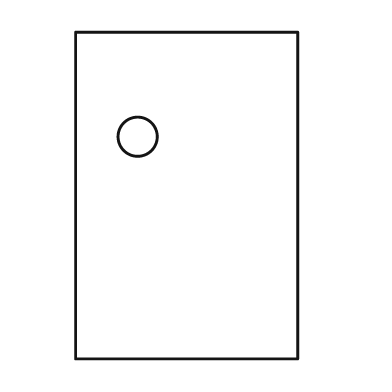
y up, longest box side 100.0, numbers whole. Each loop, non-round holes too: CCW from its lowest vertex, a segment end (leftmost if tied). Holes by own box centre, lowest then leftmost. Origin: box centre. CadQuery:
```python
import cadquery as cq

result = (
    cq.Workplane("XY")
    .moveTo(-34.0, -50.0)
    .lineTo(34.0, -50.0)
    .lineTo(34.0, 50.0)
    .lineTo(-34.0, 50.0)
    .close()
    .moveTo(-15.0, 18.0)
    .circle(6.0)
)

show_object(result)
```